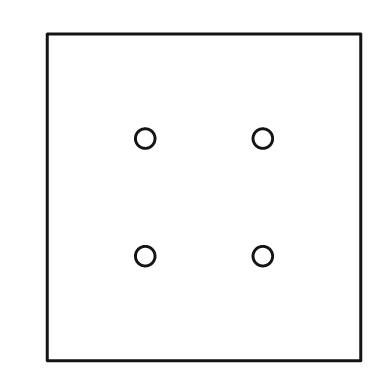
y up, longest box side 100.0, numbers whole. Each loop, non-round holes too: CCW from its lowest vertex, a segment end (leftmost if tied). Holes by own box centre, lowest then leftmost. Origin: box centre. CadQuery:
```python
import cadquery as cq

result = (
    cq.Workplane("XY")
    .moveTo(-48.0, -50.0)
    .lineTo(48.0, -50.0)
    .lineTo(48.0, 50.0)
    .lineTo(-48.0, 50.0)
    .close()
    .moveTo(-18.0, -18.0)
    .circle(3.0)
    .moveTo(18.0, -18.0)
    .circle(3.0)
    .moveTo(-18.0, 18.0)
    .circle(3.0)
    .moveTo(18.0, 18.0)
    .circle(3.0)
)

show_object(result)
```